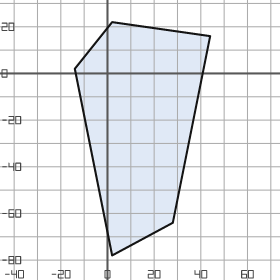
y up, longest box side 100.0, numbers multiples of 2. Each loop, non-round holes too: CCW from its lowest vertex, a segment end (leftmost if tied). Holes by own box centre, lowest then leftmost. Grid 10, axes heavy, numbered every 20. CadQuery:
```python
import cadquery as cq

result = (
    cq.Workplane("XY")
    .moveTo(2.0, -78.0)
    .lineTo(28.0, -64.0)
    .lineTo(44.0, 16.0)
    .lineTo(2.0, 22.0)
    .lineTo(-14.0, 2.0)
    .close()
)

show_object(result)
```